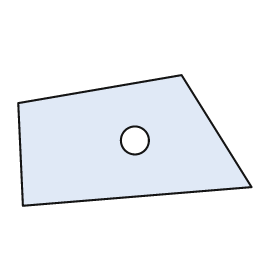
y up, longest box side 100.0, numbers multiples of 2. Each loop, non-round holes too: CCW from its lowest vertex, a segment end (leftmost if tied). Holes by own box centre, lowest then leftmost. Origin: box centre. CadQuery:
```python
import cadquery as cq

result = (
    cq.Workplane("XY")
    .moveTo(-48.0, -28.0)
    .lineTo(50.0, -20.0)
    .lineTo(20.0, 28.0)
    .lineTo(-50.0, 16.0)
    .close()
    .moveTo(0.0, 0.0)
    .circle(6.0)
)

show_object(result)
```